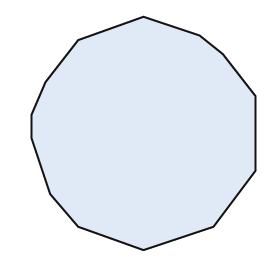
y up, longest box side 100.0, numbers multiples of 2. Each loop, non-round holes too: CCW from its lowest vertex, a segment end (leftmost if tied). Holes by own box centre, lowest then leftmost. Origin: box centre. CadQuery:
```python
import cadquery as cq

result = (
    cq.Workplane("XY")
    .moveTo(0.0, -50.0)
    .lineTo(30.0, -40.0)
    .lineTo(48.0, -16.0)
    .lineTo(48.0, 16.0)
    .lineTo(34.0, 34.0)
    .lineTo(24.0, 42.0)
    .lineTo(0.0, 50.0)
    .lineTo(-28.0, 40.0)
    .lineTo(-42.0, 22.0)
    .lineTo(-48.0, 8.0)
    .lineTo(-48.0, -2.0)
    .lineTo(-40.0, -26.0)
    .lineTo(-28.0, -40.0)
    .close()
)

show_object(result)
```